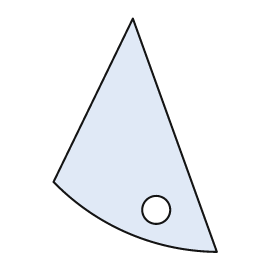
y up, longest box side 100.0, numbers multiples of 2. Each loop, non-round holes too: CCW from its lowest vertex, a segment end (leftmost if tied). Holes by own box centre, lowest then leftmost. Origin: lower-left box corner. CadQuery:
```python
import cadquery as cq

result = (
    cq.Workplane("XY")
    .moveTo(70.0, 0.0)
    .lineTo(34.0, 100.0)
    .lineTo(0.0, 30.0)
    .threePointArc((32.0, 8.0), (70.0, 0.0))
    .close()
    .moveTo(44.0, 18.0)
    .circle(6.0)
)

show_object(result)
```